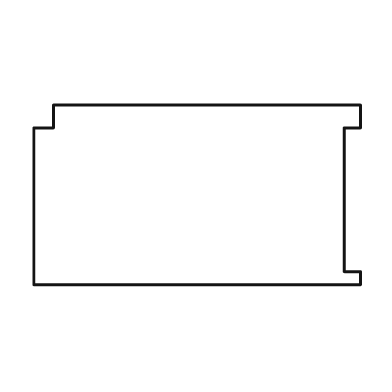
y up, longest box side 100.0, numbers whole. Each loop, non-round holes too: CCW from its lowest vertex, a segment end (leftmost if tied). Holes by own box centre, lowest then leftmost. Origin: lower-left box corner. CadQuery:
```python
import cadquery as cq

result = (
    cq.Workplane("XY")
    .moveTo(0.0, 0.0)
    .lineTo(100.0, 0.0)
    .lineTo(100.0, 4.0)
    .lineTo(95.0, 4.0)
    .lineTo(95.0, 48.0)
    .lineTo(100.0, 48.0)
    .lineTo(100.0, 55.0)
    .lineTo(6.0, 55.0)
    .lineTo(6.0, 48.0)
    .lineTo(0.0, 48.0)
    .close()
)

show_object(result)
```